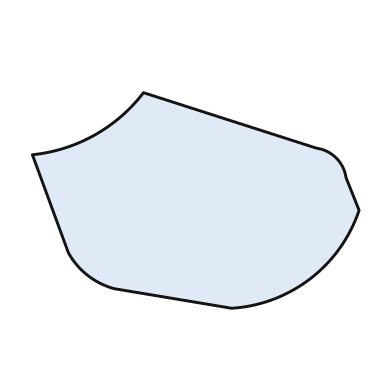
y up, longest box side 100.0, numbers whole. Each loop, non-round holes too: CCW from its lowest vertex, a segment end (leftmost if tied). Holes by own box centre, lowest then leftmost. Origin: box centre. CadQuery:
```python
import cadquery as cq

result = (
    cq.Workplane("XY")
    .moveTo(11.0, -33.0)
    .threePointArc((35.0, -24.0), (50.0, -3.0))
    .lineTo(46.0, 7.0)
    .threePointArc((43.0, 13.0), (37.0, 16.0))
    .lineTo(-16.0, 33.0)
    .threePointArc((-31.0, 20.0), (-50.0, 14.0))
    .lineTo(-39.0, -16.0)
    .threePointArc((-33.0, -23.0), (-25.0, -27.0))
    .close()
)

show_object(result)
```